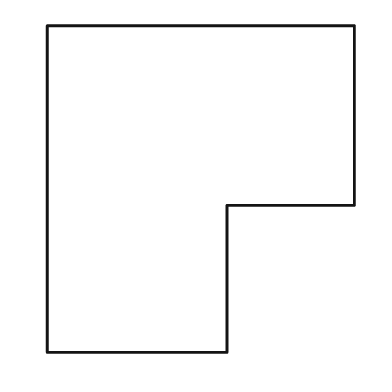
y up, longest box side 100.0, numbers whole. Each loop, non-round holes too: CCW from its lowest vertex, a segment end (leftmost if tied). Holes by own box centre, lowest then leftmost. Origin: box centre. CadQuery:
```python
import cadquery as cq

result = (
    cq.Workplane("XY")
    .moveTo(-47.0, -50.0)
    .lineTo(8.0, -50.0)
    .lineTo(8.0, -5.0)
    .lineTo(47.0, -5.0)
    .lineTo(47.0, 50.0)
    .lineTo(-47.0, 50.0)
    .close()
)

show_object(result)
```